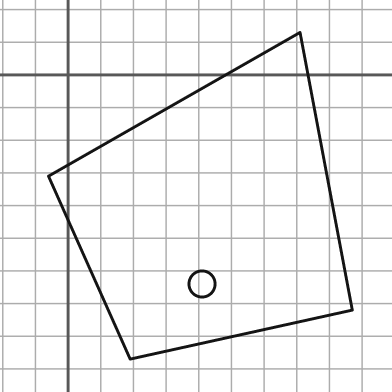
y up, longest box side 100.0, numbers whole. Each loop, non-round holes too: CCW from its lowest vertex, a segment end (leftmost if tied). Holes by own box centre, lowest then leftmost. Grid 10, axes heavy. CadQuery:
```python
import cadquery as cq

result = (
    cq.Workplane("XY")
    .moveTo(19.0, -87.0)
    .lineTo(87.0, -72.0)
    .lineTo(71.0, 13.0)
    .lineTo(-6.0, -31.0)
    .close()
    .moveTo(41.0, -64.0)
    .circle(4.0)
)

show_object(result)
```